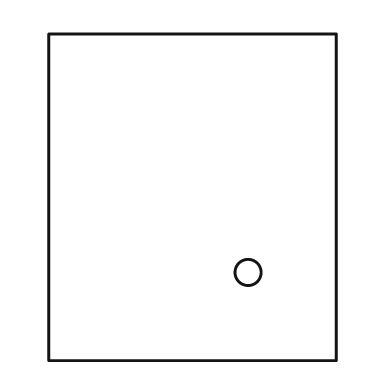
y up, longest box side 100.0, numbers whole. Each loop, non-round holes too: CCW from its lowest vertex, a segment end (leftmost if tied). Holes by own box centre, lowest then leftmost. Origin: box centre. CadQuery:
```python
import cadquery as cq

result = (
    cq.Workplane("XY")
    .moveTo(-44.0, -50.0)
    .lineTo(44.0, -50.0)
    .lineTo(44.0, 50.0)
    .lineTo(-44.0, 50.0)
    .close()
    .moveTo(17.0, -23.0)
    .circle(4.0)
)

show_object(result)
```